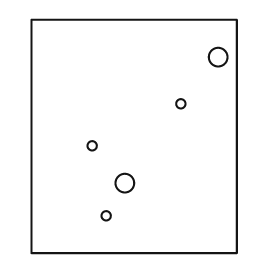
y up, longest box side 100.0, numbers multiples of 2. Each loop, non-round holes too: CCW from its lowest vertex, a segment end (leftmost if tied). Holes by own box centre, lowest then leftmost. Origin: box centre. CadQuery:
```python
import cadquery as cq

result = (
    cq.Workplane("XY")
    .moveTo(-44.0, -50.0)
    .lineTo(44.0, -50.0)
    .lineTo(44.0, 50.0)
    .lineTo(-44.0, 50.0)
    .close()
    .moveTo(-12.0, -34.0)
    .circle(2.0)
    .moveTo(-4.0, -20.0)
    .circle(4.0)
    .moveTo(-18.0, -4.0)
    .circle(2.0)
    .moveTo(20.0, 14.0)
    .circle(2.0)
    .moveTo(36.0, 34.0)
    .circle(4.0)
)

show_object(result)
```